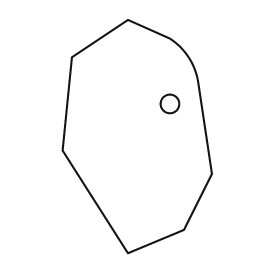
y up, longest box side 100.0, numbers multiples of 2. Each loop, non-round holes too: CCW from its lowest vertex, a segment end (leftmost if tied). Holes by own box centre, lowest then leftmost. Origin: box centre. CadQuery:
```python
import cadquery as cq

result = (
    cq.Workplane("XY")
    .moveTo(-4.0, -50.0)
    .lineTo(20.0, -40.0)
    .lineTo(32.0, -16.0)
    .lineTo(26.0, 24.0)
    .threePointArc((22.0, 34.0), (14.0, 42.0))
    .lineTo(-4.0, 50.0)
    .lineTo(-28.0, 34.0)
    .lineTo(-32.0, -6.0)
    .close()
    .moveTo(14.0, 14.0)
    .circle(4.0)
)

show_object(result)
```